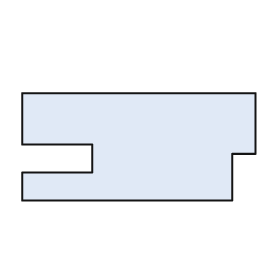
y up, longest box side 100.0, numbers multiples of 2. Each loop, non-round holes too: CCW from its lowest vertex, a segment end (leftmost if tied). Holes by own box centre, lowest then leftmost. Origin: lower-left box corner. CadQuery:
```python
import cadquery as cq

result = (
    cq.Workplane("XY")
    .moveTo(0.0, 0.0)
    .lineTo(90.0, 0.0)
    .lineTo(90.0, 20.0)
    .lineTo(100.0, 20.0)
    .lineTo(100.0, 46.0)
    .lineTo(0.0, 46.0)
    .lineTo(0.0, 24.0)
    .lineTo(30.0, 24.0)
    .lineTo(30.0, 12.0)
    .lineTo(0.0, 12.0)
    .close()
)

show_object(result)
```